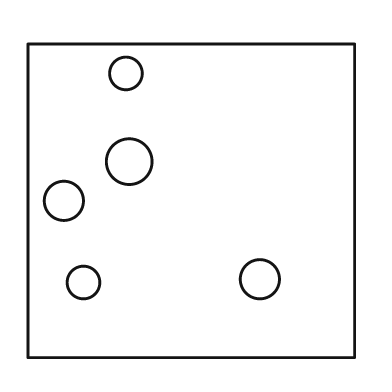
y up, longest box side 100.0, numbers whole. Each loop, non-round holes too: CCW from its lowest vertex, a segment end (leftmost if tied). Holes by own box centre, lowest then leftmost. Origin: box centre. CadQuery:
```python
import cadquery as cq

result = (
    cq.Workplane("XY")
    .moveTo(-50.0, -48.0)
    .lineTo(50.0, -48.0)
    .lineTo(50.0, 48.0)
    .lineTo(-50.0, 48.0)
    .close()
    .moveTo(-33.0, -25.0)
    .circle(5.0)
    .moveTo(21.0, -24.0)
    .circle(6.0)
    .moveTo(-39.0, 0.0)
    .circle(6.0)
    .moveTo(-19.0, 12.0)
    .circle(7.0)
    .moveTo(-20.0, 39.0)
    .circle(5.0)
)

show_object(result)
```